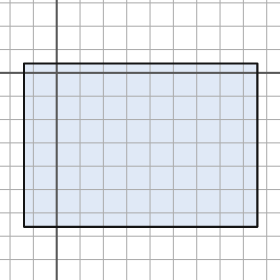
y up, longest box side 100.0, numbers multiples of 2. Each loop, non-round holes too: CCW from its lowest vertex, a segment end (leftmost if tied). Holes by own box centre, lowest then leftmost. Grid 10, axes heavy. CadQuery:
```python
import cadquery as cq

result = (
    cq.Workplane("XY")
    .moveTo(-14.0, -66.0)
    .lineTo(86.0, -66.0)
    .lineTo(86.0, 4.0)
    .lineTo(-14.0, 4.0)
    .close()
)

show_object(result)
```